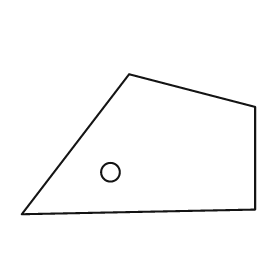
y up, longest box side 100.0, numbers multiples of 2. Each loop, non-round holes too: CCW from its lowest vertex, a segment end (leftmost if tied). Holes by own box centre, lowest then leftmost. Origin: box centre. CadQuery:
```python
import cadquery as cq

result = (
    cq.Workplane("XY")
    .moveTo(-50.0, -30.0)
    .lineTo(50.0, -28.0)
    .lineTo(50.0, 16.0)
    .lineTo(-4.0, 30.0)
    .close()
    .moveTo(-12.0, -12.0)
    .circle(4.0)
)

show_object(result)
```